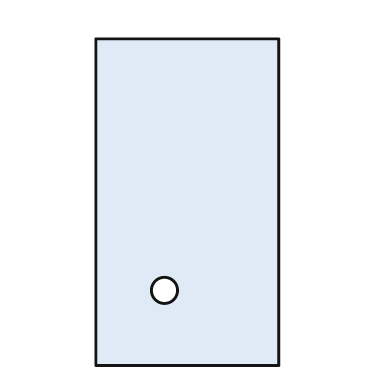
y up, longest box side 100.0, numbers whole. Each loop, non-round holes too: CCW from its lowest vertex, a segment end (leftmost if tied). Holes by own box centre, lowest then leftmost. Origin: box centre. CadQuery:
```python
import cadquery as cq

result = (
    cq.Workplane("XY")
    .moveTo(-28.0, -50.0)
    .lineTo(28.0, -50.0)
    .lineTo(28.0, 50.0)
    .lineTo(-28.0, 50.0)
    .close()
    .moveTo(-7.0, -27.0)
    .circle(4.0)
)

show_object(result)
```